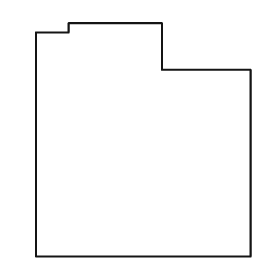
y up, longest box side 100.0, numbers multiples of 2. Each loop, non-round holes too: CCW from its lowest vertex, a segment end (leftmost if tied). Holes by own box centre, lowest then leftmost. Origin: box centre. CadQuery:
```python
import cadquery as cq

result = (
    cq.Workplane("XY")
    .moveTo(-46.0, -50.0)
    .lineTo(46.0, -50.0)
    .lineTo(46.0, 30.0)
    .lineTo(8.0, 30.0)
    .lineTo(8.0, 50.0)
    .lineTo(-32.0, 50.0)
    .lineTo(-32.0, 46.0)
    .lineTo(-46.0, 46.0)
    .close()
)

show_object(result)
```